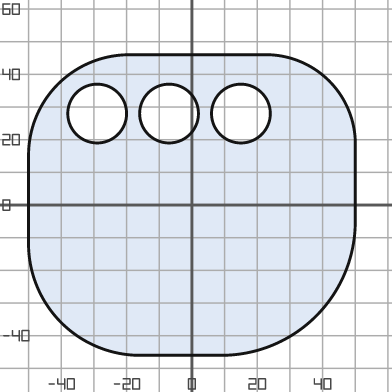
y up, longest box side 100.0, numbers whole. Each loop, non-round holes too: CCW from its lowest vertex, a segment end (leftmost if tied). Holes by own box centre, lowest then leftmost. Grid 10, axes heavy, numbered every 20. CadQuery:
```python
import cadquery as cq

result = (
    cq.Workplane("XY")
    .moveTo(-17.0, -46.0)
    .lineTo(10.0, -46.0)
    .threePointArc((38.0, -34.0), (50.0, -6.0))
    .lineTo(50.0, 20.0)
    .threePointArc((42.0, 38.0), (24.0, 46.0))
    .lineTo(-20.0, 46.0)
    .threePointArc((-41.0, 37.0), (-50.0, 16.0))
    .lineTo(-50.0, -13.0)
    .threePointArc((-40.0, -36.0), (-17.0, -46.0))
    .close()
    .moveTo(-29.0, 28.0)
    .circle(9.0)
    .moveTo(-7.0, 28.0)
    .circle(9.0)
    .moveTo(15.0, 28.0)
    .circle(9.0)
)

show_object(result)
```